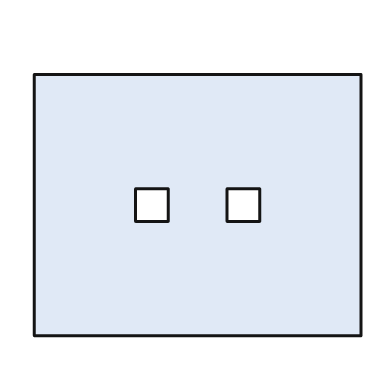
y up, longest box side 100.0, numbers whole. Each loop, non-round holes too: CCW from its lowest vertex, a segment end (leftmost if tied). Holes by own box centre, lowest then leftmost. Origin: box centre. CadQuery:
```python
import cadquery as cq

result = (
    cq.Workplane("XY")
    .moveTo(-50.0, -40.0)
    .lineTo(50.0, -40.0)
    .lineTo(50.0, 40.0)
    .lineTo(-50.0, 40.0)
    .close()
    .moveTo(-19.0, -5.0)
    .lineTo(-9.0, -5.0)
    .lineTo(-9.0, 5.0)
    .lineTo(-19.0, 5.0)
    .close()
    .moveTo(9.0, -5.0)
    .lineTo(19.0, -5.0)
    .lineTo(19.0, 5.0)
    .lineTo(9.0, 5.0)
    .close()
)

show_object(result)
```